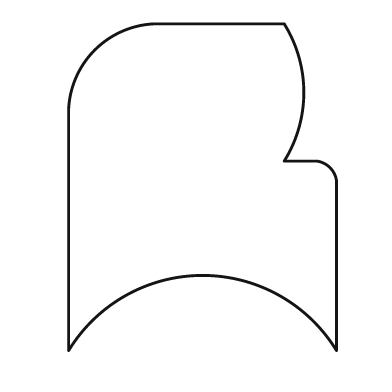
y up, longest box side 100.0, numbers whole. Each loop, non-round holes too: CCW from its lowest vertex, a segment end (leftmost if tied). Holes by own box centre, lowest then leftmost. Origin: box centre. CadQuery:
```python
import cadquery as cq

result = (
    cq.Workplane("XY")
    .moveTo(-41.0, -50.0)
    .threePointArc((0.0, -27.0), (41.0, -50.0))
    .lineTo(41.0, 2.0)
    .threePointArc((39.0, 6.0), (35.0, 8.0))
    .lineTo(25.0, 8.0)
    .threePointArc((31.0, 29.0), (25.0, 50.0))
    .lineTo(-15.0, 50.0)
    .threePointArc((-33.0, 42.0), (-41.0, 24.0))
    .close()
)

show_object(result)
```